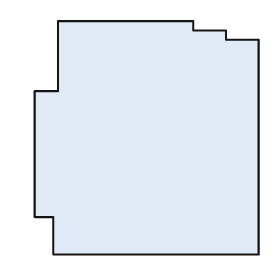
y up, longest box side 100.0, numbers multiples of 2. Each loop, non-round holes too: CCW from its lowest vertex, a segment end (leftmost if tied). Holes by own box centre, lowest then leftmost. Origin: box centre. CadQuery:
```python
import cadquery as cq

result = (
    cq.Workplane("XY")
    .moveTo(-40.0, -50.0)
    .lineTo(48.0, -50.0)
    .lineTo(48.0, 42.0)
    .lineTo(34.0, 42.0)
    .lineTo(34.0, 46.0)
    .lineTo(20.0, 46.0)
    .lineTo(20.0, 50.0)
    .lineTo(-38.0, 50.0)
    .lineTo(-38.0, 20.0)
    .lineTo(-48.0, 20.0)
    .lineTo(-48.0, -34.0)
    .lineTo(-40.0, -34.0)
    .close()
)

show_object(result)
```